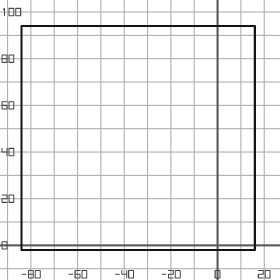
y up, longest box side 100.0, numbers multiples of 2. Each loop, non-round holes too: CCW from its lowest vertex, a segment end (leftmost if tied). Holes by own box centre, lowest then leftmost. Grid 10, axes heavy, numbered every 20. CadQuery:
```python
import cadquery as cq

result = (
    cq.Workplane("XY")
    .moveTo(-84.0, -2.0)
    .lineTo(16.0, -2.0)
    .lineTo(16.0, 94.0)
    .lineTo(-84.0, 94.0)
    .close()
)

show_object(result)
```